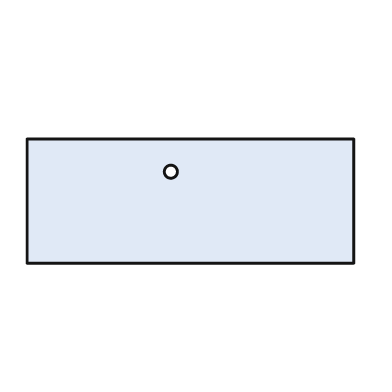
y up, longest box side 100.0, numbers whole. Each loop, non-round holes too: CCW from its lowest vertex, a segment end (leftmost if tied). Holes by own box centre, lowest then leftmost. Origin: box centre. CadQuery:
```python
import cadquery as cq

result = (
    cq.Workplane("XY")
    .moveTo(-50.0, -19.0)
    .lineTo(50.0, -19.0)
    .lineTo(50.0, 19.0)
    .lineTo(-50.0, 19.0)
    .close()
    .moveTo(-6.0, 9.0)
    .circle(2.0)
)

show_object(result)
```